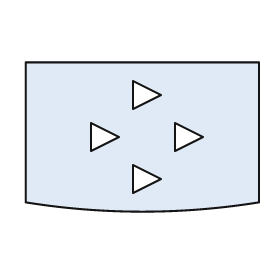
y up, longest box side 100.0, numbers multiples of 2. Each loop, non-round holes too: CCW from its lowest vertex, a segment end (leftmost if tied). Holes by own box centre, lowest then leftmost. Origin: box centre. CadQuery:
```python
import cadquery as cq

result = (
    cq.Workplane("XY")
    .moveTo(-50.0, -28.0)
    .threePointArc((0.0, -32.0), (50.0, -28.0))
    .lineTo(50.0, 32.0)
    .lineTo(-50.0, 32.0)
    .close()
    .moveTo(-4.0, -24.0)
    .lineTo(8.0, -18.0)
    .lineTo(-4.0, -12.0)
    .close()
    .moveTo(-22.0, -6.0)
    .lineTo(-10.0, 0.0)
    .lineTo(-22.0, 6.0)
    .close()
    .moveTo(14.0, -6.0)
    .lineTo(26.0, 0.0)
    .lineTo(14.0, 6.0)
    .close()
    .moveTo(-4.0, 12.0)
    .lineTo(8.0, 18.0)
    .lineTo(-4.0, 24.0)
    .close()
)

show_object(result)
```